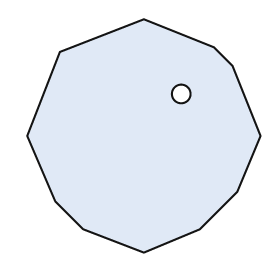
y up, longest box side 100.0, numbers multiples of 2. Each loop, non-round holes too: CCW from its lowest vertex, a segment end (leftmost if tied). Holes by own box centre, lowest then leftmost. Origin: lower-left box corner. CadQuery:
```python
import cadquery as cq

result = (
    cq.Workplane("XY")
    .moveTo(50.0, 0.0)
    .lineTo(74.0, 10.0)
    .lineTo(90.0, 26.0)
    .lineTo(100.0, 50.0)
    .lineTo(88.0, 80.0)
    .lineTo(80.0, 88.0)
    .lineTo(50.0, 100.0)
    .lineTo(14.0, 86.0)
    .lineTo(0.0, 50.0)
    .lineTo(12.0, 22.0)
    .lineTo(24.0, 10.0)
    .close()
    .moveTo(66.0, 68.0)
    .circle(4.0)
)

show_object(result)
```